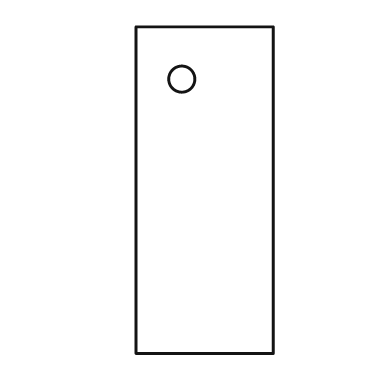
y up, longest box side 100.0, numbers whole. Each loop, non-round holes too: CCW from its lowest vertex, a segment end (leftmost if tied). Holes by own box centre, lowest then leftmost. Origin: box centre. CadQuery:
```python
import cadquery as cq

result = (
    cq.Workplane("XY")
    .moveTo(-21.0, -50.0)
    .lineTo(21.0, -50.0)
    .lineTo(21.0, 50.0)
    .lineTo(-21.0, 50.0)
    .close()
    .moveTo(-7.0, 34.0)
    .circle(4.0)
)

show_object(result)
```